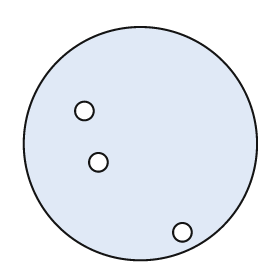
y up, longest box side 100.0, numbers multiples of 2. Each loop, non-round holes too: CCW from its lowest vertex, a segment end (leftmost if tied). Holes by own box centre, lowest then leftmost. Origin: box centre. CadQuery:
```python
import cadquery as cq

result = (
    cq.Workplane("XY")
    .moveTo(0.0, 0.0)
    .circle(50.0)
    .moveTo(18.0, -38.0)
    .circle(4.0)
    .moveTo(-18.0, -8.0)
    .circle(4.0)
    .moveTo(-24.0, 14.0)
    .circle(4.0)
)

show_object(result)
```